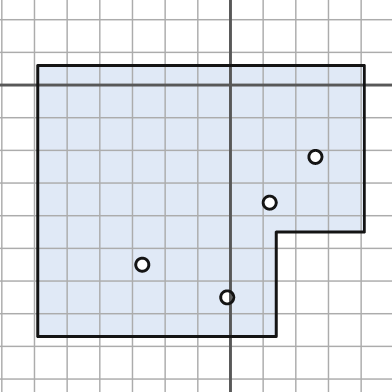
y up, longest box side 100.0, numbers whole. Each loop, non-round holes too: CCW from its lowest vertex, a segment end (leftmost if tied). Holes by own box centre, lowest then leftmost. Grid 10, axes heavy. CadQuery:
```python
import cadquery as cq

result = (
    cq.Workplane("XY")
    .moveTo(-59.0, -77.0)
    .lineTo(14.0, -77.0)
    .lineTo(14.0, -45.0)
    .lineTo(41.0, -45.0)
    .lineTo(41.0, 6.0)
    .lineTo(-59.0, 6.0)
    .close()
    .moveTo(-1.0, -65.0)
    .circle(2.0)
    .moveTo(-27.0, -55.0)
    .circle(2.0)
    .moveTo(12.0, -36.0)
    .circle(2.0)
    .moveTo(26.0, -22.0)
    .circle(2.0)
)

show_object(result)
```